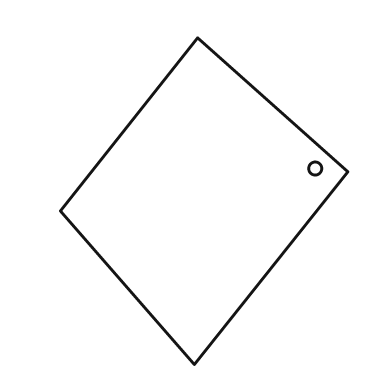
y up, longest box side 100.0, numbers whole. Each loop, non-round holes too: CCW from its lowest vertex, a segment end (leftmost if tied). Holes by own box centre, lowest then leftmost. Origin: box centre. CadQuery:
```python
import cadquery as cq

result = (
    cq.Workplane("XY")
    .moveTo(-3.0, -50.0)
    .lineTo(44.0, 9.0)
    .lineTo(-2.0, 50.0)
    .lineTo(-44.0, -3.0)
    .close()
    .moveTo(34.0, 10.0)
    .circle(2.0)
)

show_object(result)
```